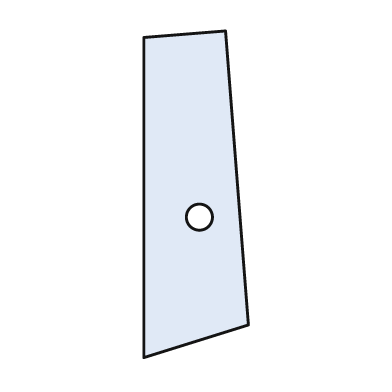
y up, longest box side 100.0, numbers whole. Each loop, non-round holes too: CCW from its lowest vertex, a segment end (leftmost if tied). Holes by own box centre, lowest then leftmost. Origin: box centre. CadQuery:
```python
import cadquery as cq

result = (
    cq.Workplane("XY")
    .moveTo(-16.0, -50.0)
    .lineTo(16.0, -40.0)
    .lineTo(9.0, 50.0)
    .lineTo(-16.0, 48.0)
    .close()
    .moveTo(1.0, -7.0)
    .circle(4.0)
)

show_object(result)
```